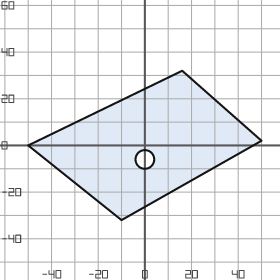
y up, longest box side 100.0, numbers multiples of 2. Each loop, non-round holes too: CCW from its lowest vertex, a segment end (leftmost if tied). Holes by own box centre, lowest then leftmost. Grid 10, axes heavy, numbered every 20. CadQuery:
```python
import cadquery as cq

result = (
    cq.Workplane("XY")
    .moveTo(-10.0, -32.0)
    .lineTo(50.0, 2.0)
    .lineTo(16.0, 32.0)
    .lineTo(-50.0, 0.0)
    .close()
    .moveTo(0.0, -6.0)
    .circle(4.0)
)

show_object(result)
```